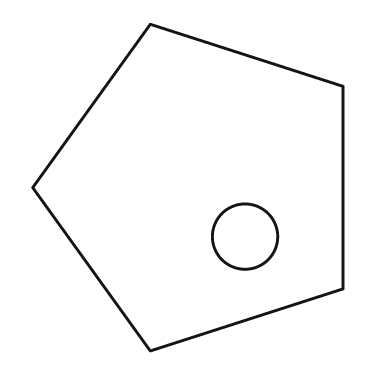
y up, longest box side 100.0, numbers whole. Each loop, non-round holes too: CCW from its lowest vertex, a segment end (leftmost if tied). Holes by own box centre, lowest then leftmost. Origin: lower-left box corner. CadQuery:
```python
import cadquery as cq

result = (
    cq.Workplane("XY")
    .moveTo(36.0, 0.0)
    .lineTo(95.0, 19.0)
    .lineTo(95.0, 81.0)
    .lineTo(36.0, 100.0)
    .lineTo(0.0, 50.0)
    .close()
    .moveTo(65.0, 35.0)
    .circle(10.0)
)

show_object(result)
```